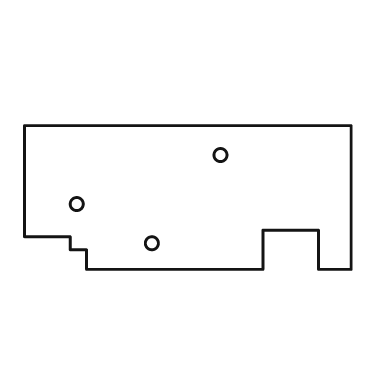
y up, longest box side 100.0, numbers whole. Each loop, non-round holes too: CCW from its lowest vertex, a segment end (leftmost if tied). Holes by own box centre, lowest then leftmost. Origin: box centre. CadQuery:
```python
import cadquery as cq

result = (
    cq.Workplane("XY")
    .moveTo(-31.0, -22.0)
    .lineTo(23.0, -22.0)
    .lineTo(23.0, -10.0)
    .lineTo(40.0, -10.0)
    .lineTo(40.0, -22.0)
    .lineTo(50.0, -22.0)
    .lineTo(50.0, 22.0)
    .lineTo(-50.0, 22.0)
    .lineTo(-50.0, -12.0)
    .lineTo(-36.0, -12.0)
    .lineTo(-36.0, -16.0)
    .lineTo(-31.0, -16.0)
    .close()
    .moveTo(-11.0, -14.0)
    .circle(2.0)
    .moveTo(-34.0, -2.0)
    .circle(2.0)
    .moveTo(10.0, 13.0)
    .circle(2.0)
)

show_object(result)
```